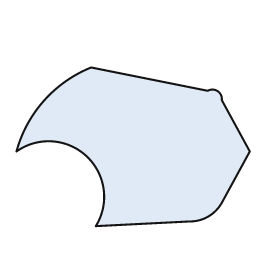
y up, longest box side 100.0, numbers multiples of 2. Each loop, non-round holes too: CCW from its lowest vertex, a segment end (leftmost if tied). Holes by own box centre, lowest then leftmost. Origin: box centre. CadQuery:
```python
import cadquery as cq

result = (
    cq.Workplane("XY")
    .moveTo(-16.0, -34.0)
    .lineTo(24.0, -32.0)
    .threePointArc((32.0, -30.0), (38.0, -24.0))
    .lineTo(50.0, -2.0)
    .lineTo(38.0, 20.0)
    .threePointArc((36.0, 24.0), (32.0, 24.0))
    .lineTo(-18.0, 34.0)
    .threePointArc((-38.0, 20.0), (-50.0, -2.0))
    .threePointArc((-20.0, -4.0), (-16.0, -34.0))
    .close()
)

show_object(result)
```